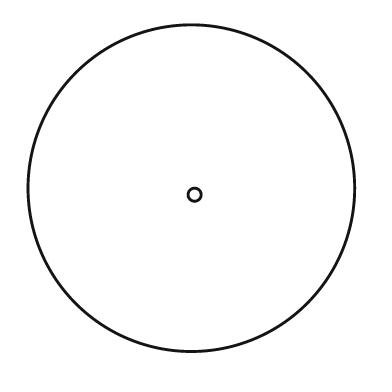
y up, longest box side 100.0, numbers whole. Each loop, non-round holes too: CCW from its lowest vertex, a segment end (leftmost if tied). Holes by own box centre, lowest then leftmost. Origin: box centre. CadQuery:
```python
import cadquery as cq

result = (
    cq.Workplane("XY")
    .moveTo(0.0, 0.0)
    .circle(50.0)
    .moveTo(1.0, -2.0)
    .circle(2.0)
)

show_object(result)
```